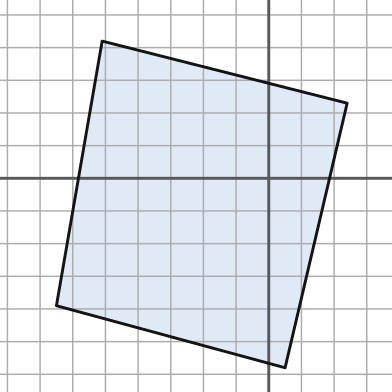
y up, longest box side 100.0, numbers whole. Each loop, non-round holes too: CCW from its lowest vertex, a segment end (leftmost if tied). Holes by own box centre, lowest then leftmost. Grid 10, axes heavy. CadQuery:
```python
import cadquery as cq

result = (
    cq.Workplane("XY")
    .moveTo(5.0, -58.0)
    .lineTo(24.0, 23.0)
    .lineTo(-51.0, 42.0)
    .lineTo(-65.0, -39.0)
    .close()
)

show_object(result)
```